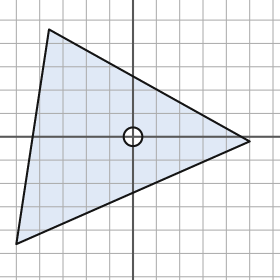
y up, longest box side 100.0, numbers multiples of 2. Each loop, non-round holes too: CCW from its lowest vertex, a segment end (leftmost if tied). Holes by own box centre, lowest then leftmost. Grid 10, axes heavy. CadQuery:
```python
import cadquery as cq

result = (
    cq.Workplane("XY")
    .moveTo(-50.0, -46.0)
    .lineTo(50.0, -2.0)
    .lineTo(-36.0, 46.0)
    .close()
    .moveTo(0.0, 0.0)
    .circle(4.0)
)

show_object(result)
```